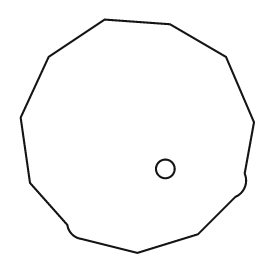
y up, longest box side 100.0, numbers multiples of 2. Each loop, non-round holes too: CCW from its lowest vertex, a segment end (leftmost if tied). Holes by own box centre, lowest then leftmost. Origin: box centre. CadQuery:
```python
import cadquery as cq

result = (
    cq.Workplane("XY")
    .moveTo(0.0, -50.0)
    .lineTo(26.0, -42.0)
    .lineTo(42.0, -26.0)
    .threePointArc((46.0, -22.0), (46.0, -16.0))
    .lineTo(50.0, 6.0)
    .lineTo(38.0, 34.0)
    .lineTo(14.0, 48.0)
    .lineTo(-14.0, 50.0)
    .lineTo(-38.0, 34.0)
    .lineTo(-50.0, 8.0)
    .lineTo(-46.0, -20.0)
    .lineTo(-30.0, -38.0)
    .threePointArc((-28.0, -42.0), (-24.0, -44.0))
    .close()
    .moveTo(12.0, -14.0)
    .circle(4.0)
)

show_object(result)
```